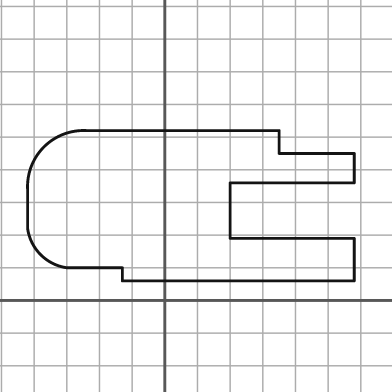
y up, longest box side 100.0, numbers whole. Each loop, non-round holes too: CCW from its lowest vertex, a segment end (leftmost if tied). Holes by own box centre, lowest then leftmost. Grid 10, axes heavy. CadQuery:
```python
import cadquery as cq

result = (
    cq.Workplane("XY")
    .moveTo(-13.0, 6.0)
    .lineTo(58.0, 6.0)
    .lineTo(58.0, 19.0)
    .lineTo(20.0, 19.0)
    .lineTo(20.0, 36.0)
    .lineTo(58.0, 36.0)
    .lineTo(58.0, 45.0)
    .lineTo(35.0, 45.0)
    .lineTo(35.0, 52.0)
    .lineTo(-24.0, 52.0)
    .threePointArc((-37.0, 47.0), (-42.0, 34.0))
    .lineTo(-42.0, 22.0)
    .threePointArc((-38.0, 14.0), (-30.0, 10.0))
    .lineTo(-13.0, 10.0)
    .close()
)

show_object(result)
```